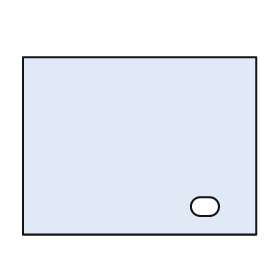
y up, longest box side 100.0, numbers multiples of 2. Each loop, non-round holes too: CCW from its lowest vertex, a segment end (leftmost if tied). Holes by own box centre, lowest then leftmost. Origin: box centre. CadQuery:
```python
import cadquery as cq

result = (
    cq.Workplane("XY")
    .moveTo(-50.0, -38.0)
    .lineTo(50.0, -38.0)
    .lineTo(50.0, 38.0)
    .lineTo(-50.0, 38.0)
    .close()
    .moveTo(26.0, -30.0)
    .lineTo(30.0, -30.0)
    .threePointArc((34.0, -26.0), (30.0, -22.0))
    .lineTo(26.0, -22.0)
    .threePointArc((22.0, -26.0), (26.0, -30.0))
    .close()
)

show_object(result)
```